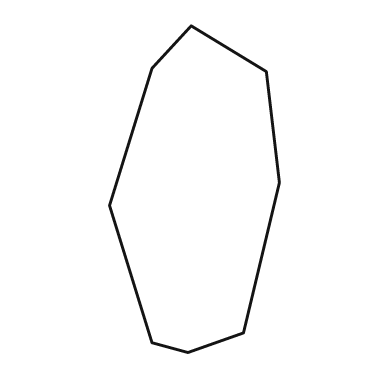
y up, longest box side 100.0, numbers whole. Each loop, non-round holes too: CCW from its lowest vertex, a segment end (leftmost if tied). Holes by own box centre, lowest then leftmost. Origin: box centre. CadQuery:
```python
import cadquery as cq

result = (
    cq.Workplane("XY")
    .moveTo(-2.0, -50.0)
    .lineTo(15.0, -44.0)
    .lineTo(26.0, 2.0)
    .lineTo(22.0, 36.0)
    .lineTo(-1.0, 50.0)
    .lineTo(-13.0, 37.0)
    .lineTo(-26.0, -5.0)
    .lineTo(-13.0, -47.0)
    .close()
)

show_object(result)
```